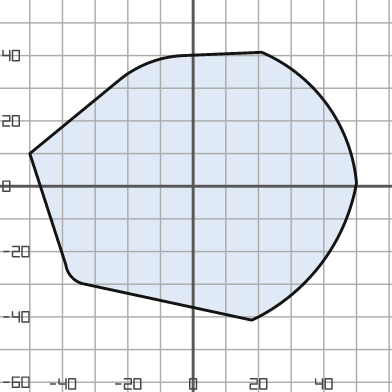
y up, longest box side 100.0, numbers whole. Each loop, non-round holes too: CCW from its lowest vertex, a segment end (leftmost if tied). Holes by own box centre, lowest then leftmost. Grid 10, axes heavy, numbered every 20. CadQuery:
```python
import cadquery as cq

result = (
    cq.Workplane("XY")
    .moveTo(18.0, -41.0)
    .threePointArc((39.0, -24.0), (50.0, 1.0))
    .threePointArc((41.0, 25.0), (21.0, 41.0))
    .lineTo(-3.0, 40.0)
    .threePointArc((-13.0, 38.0), (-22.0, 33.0))
    .lineTo(-50.0, 10.0)
    .lineTo(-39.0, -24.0)
    .threePointArc((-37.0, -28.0), (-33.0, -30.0))
    .close()
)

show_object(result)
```